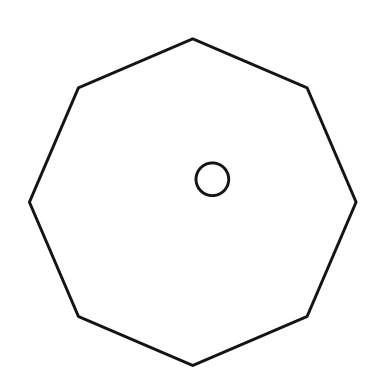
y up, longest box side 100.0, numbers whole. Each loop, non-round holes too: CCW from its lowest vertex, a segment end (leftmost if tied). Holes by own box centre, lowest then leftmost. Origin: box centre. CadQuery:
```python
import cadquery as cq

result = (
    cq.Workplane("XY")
    .moveTo(0.0, -50.0)
    .lineTo(35.0, -35.0)
    .lineTo(50.0, 0.0)
    .lineTo(35.0, 35.0)
    .lineTo(0.0, 50.0)
    .lineTo(-35.0, 35.0)
    .lineTo(-50.0, 0.0)
    .lineTo(-35.0, -35.0)
    .close()
    .moveTo(6.0, 7.0)
    .circle(5.0)
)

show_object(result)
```